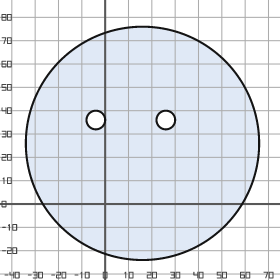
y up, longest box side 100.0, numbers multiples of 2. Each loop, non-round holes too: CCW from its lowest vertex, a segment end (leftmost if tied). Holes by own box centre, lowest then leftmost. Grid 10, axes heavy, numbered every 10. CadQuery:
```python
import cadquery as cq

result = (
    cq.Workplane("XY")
    .moveTo(16.0, 26.0)
    .circle(50.0)
    .moveTo(-4.0, 36.0)
    .circle(4.0)
    .moveTo(26.0, 36.0)
    .circle(4.0)
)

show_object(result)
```